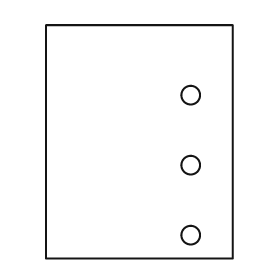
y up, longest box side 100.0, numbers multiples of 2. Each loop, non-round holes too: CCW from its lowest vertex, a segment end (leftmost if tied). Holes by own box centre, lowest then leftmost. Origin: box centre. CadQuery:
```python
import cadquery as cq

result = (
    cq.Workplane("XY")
    .moveTo(-40.0, -50.0)
    .lineTo(40.0, -50.0)
    .lineTo(40.0, 50.0)
    .lineTo(-40.0, 50.0)
    .close()
    .moveTo(22.0, -40.0)
    .circle(4.0)
    .moveTo(22.0, -10.0)
    .circle(4.0)
    .moveTo(22.0, 20.0)
    .circle(4.0)
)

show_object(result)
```